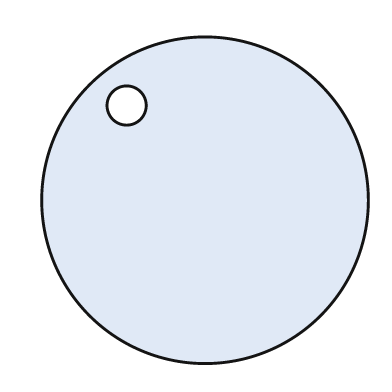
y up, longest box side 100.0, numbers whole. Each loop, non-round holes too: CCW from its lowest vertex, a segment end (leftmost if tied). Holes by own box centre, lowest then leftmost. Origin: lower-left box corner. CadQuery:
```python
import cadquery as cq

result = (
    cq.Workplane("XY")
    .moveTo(50.0, 50.0)
    .circle(50.0)
    .moveTo(26.0, 79.0)
    .circle(6.0)
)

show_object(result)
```